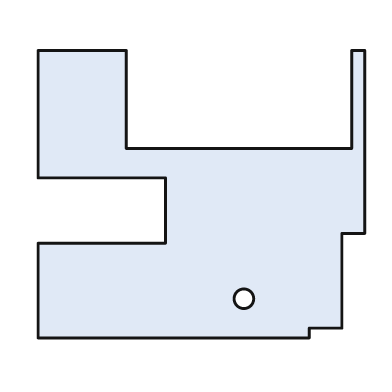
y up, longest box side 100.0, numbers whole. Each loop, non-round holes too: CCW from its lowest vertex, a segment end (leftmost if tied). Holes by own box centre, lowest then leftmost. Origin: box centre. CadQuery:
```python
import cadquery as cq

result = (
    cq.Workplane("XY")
    .moveTo(-50.0, -44.0)
    .lineTo(33.0, -44.0)
    .lineTo(33.0, -41.0)
    .lineTo(43.0, -41.0)
    .lineTo(43.0, -12.0)
    .lineTo(50.0, -12.0)
    .lineTo(50.0, 44.0)
    .lineTo(46.0, 44.0)
    .lineTo(46.0, 14.0)
    .lineTo(-23.0, 14.0)
    .lineTo(-23.0, 44.0)
    .lineTo(-50.0, 44.0)
    .lineTo(-50.0, 5.0)
    .lineTo(-11.0, 5.0)
    .lineTo(-11.0, -15.0)
    .lineTo(-50.0, -15.0)
    .close()
    .moveTo(13.0, -32.0)
    .circle(3.0)
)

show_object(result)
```